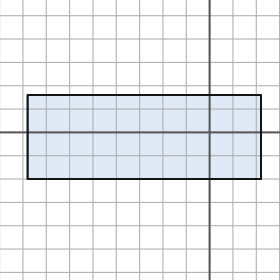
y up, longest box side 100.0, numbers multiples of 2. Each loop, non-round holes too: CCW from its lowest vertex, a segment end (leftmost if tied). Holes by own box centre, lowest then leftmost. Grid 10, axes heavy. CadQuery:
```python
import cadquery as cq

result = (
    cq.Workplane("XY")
    .moveTo(-78.0, -20.0)
    .lineTo(22.0, -20.0)
    .lineTo(22.0, 16.0)
    .lineTo(-78.0, 16.0)
    .close()
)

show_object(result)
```